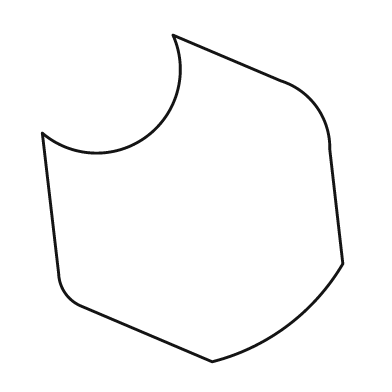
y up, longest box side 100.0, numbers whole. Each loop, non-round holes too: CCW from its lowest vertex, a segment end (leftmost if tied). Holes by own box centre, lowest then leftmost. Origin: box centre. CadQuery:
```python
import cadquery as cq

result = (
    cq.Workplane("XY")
    .moveTo(6.0, -50.0)
    .threePointArc((29.0, -39.0), (46.0, -20.0))
    .lineTo(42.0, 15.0)
    .threePointArc((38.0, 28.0), (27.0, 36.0))
    .lineTo(-6.0, 50.0)
    .threePointArc((-14.0, 19.0), (-46.0, 20.0))
    .lineTo(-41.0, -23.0)
    .threePointArc((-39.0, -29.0), (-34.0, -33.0))
    .close()
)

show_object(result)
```